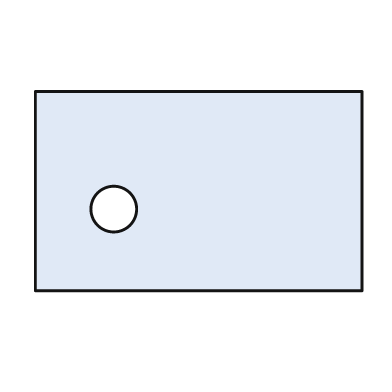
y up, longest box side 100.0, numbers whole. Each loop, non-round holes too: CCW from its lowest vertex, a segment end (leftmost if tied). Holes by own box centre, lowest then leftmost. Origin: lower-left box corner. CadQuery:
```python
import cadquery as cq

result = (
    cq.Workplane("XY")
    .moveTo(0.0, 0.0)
    .lineTo(100.0, 0.0)
    .lineTo(100.0, 61.0)
    .lineTo(0.0, 61.0)
    .close()
    .moveTo(24.0, 25.0)
    .circle(7.0)
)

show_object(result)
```